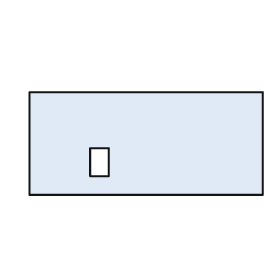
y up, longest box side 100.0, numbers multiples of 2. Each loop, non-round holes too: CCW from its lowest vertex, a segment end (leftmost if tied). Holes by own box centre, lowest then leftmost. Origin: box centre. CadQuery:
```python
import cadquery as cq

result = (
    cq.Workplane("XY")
    .moveTo(-50.0, -22.0)
    .lineTo(50.0, -22.0)
    .lineTo(50.0, 22.0)
    .lineTo(-50.0, 22.0)
    .close()
    .moveTo(-24.0, -14.0)
    .lineTo(-16.0, -14.0)
    .lineTo(-16.0, -2.0)
    .lineTo(-24.0, -2.0)
    .close()
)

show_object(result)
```